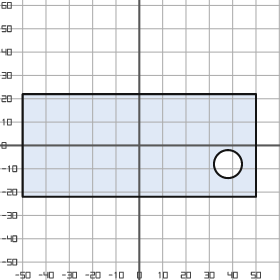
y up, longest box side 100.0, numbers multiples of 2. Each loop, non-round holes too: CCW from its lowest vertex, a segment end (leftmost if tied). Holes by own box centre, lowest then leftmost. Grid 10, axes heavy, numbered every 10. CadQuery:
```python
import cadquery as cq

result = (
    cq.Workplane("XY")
    .moveTo(-50.0, -22.0)
    .lineTo(50.0, -22.0)
    .lineTo(50.0, 22.0)
    .lineTo(-50.0, 22.0)
    .close()
    .moveTo(38.0, -8.0)
    .circle(6.0)
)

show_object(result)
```